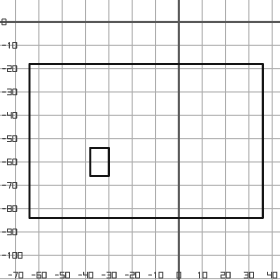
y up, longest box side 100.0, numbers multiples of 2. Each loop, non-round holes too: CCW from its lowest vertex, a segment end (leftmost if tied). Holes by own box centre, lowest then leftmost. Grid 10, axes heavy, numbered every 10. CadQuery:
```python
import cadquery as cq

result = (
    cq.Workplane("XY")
    .moveTo(-64.0, -84.0)
    .lineTo(36.0, -84.0)
    .lineTo(36.0, -18.0)
    .lineTo(-64.0, -18.0)
    .close()
    .moveTo(-38.0, -66.0)
    .lineTo(-30.0, -66.0)
    .lineTo(-30.0, -54.0)
    .lineTo(-38.0, -54.0)
    .close()
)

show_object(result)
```